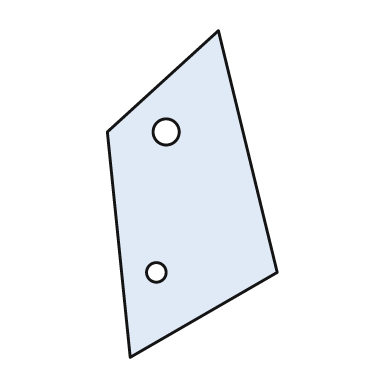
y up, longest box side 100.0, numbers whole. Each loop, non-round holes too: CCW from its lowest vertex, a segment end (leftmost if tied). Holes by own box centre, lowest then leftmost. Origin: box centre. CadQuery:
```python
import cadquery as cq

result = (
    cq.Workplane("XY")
    .moveTo(-19.0, -50.0)
    .lineTo(26.0, -24.0)
    .lineTo(8.0, 50.0)
    .lineTo(-26.0, 19.0)
    .close()
    .moveTo(-11.0, -24.0)
    .circle(3.0)
    .moveTo(-8.0, 19.0)
    .circle(4.0)
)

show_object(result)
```